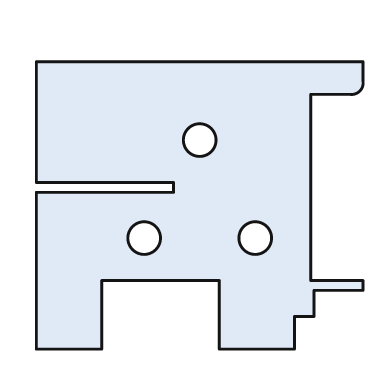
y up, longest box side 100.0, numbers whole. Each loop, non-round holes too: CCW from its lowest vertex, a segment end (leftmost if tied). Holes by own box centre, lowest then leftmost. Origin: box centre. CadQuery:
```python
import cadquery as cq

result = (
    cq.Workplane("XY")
    .moveTo(-50.0, -44.0)
    .lineTo(-30.0, -44.0)
    .lineTo(-30.0, -23.0)
    .lineTo(6.0, -23.0)
    .lineTo(6.0, -44.0)
    .lineTo(29.0, -44.0)
    .lineTo(29.0, -34.0)
    .lineTo(35.0, -34.0)
    .lineTo(35.0, -26.0)
    .lineTo(50.0, -26.0)
    .lineTo(50.0, -23.0)
    .lineTo(34.0, -23.0)
    .lineTo(34.0, 34.0)
    .lineTo(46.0, 34.0)
    .threePointArc((49.0, 35.0), (50.0, 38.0))
    .lineTo(50.0, 44.0)
    .lineTo(-50.0, 44.0)
    .lineTo(-50.0, 7.0)
    .lineTo(-8.0, 7.0)
    .lineTo(-8.0, 4.0)
    .lineTo(-50.0, 4.0)
    .close()
    .moveTo(-17.0, -10.0)
    .circle(5.0)
    .moveTo(17.0, -10.0)
    .circle(5.0)
    .moveTo(0.0, 20.0)
    .circle(5.0)
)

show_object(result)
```